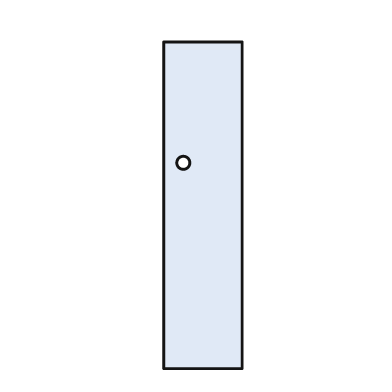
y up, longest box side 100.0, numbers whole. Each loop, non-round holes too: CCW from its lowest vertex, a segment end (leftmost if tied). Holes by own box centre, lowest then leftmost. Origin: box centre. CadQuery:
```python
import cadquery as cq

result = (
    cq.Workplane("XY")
    .moveTo(-12.0, -50.0)
    .lineTo(12.0, -50.0)
    .lineTo(12.0, 50.0)
    .lineTo(-12.0, 50.0)
    .close()
    .moveTo(-6.0, 13.0)
    .circle(2.0)
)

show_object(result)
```